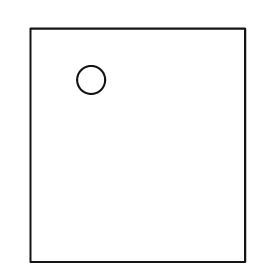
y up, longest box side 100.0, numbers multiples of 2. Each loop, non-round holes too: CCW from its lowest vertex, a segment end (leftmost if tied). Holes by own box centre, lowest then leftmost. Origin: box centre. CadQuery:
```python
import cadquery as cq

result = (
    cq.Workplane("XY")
    .moveTo(-46.0, -50.0)
    .lineTo(46.0, -50.0)
    .lineTo(46.0, 50.0)
    .lineTo(-46.0, 50.0)
    .close()
    .moveTo(-20.0, 28.0)
    .circle(6.0)
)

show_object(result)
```